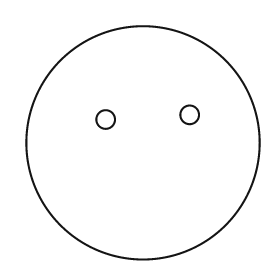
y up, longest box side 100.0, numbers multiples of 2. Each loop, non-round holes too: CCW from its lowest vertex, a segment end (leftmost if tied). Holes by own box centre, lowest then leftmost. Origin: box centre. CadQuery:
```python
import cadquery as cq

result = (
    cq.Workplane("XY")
    .moveTo(0.0, 0.0)
    .circle(50.0)
    .moveTo(-16.0, 10.0)
    .circle(4.0)
    .moveTo(20.0, 12.0)
    .circle(4.0)
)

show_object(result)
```